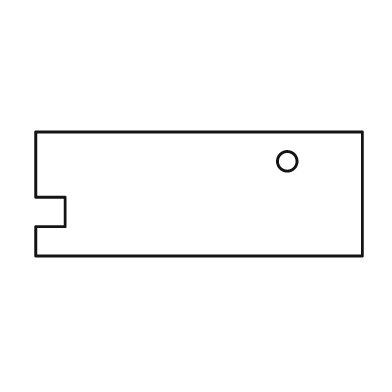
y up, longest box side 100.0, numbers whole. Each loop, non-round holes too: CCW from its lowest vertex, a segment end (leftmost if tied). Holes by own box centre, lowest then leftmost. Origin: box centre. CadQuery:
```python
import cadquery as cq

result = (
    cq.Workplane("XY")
    .moveTo(-50.0, -19.0)
    .lineTo(50.0, -19.0)
    .lineTo(50.0, 19.0)
    .lineTo(-50.0, 19.0)
    .lineTo(-50.0, -1.0)
    .lineTo(-41.0, -1.0)
    .lineTo(-41.0, -10.0)
    .lineTo(-50.0, -10.0)
    .close()
    .moveTo(27.0, 10.0)
    .circle(3.0)
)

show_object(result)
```